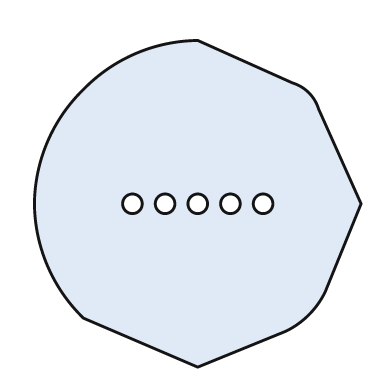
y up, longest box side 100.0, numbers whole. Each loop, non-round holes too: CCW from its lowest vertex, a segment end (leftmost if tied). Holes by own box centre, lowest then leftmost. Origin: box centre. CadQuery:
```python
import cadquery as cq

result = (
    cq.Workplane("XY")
    .moveTo(0.0, -50.0)
    .lineTo(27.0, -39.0)
    .threePointArc((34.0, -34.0), (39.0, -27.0))
    .lineTo(50.0, 0.0)
    .lineTo(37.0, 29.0)
    .threePointArc((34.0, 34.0), (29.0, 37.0))
    .lineTo(0.0, 50.0)
    .threePointArc((-19.0, 46.0), (-35.0, 35.0))
    .threePointArc((-46.0, 19.0), (-50.0, 0.0))
    .threePointArc((-46.0, -19.0), (-35.0, -35.0))
    .close()
    .moveTo(-20.0, 0.0)
    .circle(3.0)
    .moveTo(-10.0, 0.0)
    .circle(3.0)
    .moveTo(0.0, 0.0)
    .circle(3.0)
    .moveTo(10.0, 0.0)
    .circle(3.0)
    .moveTo(20.0, 0.0)
    .circle(3.0)
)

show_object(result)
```